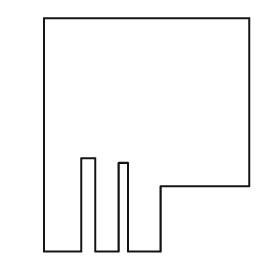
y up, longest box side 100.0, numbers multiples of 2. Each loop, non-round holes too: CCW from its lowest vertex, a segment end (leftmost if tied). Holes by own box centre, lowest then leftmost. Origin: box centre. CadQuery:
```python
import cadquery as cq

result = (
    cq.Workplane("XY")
    .moveTo(-44.0, -50.0)
    .lineTo(-28.0, -50.0)
    .lineTo(-28.0, -10.0)
    .lineTo(-22.0, -10.0)
    .lineTo(-22.0, -50.0)
    .lineTo(-12.0, -50.0)
    .lineTo(-12.0, -12.0)
    .lineTo(-8.0, -12.0)
    .lineTo(-8.0, -50.0)
    .lineTo(6.0, -50.0)
    .lineTo(6.0, -22.0)
    .lineTo(44.0, -22.0)
    .lineTo(44.0, 50.0)
    .lineTo(-44.0, 50.0)
    .close()
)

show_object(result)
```